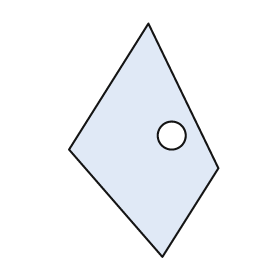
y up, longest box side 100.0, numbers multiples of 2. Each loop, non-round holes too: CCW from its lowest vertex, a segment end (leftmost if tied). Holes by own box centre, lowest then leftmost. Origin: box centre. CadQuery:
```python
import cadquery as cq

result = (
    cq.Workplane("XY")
    .moveTo(8.0, -50.0)
    .lineTo(32.0, -12.0)
    .lineTo(2.0, 50.0)
    .lineTo(-32.0, -4.0)
    .close()
    .moveTo(12.0, 2.0)
    .circle(6.0)
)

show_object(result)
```